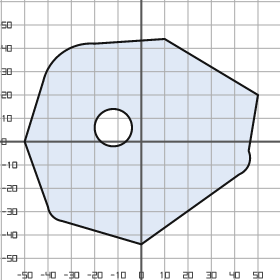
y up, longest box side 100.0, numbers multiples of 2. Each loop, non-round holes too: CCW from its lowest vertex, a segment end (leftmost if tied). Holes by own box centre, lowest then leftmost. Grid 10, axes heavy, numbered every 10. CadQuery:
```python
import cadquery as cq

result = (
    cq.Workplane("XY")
    .moveTo(0.0, -44.0)
    .lineTo(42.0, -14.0)
    .threePointArc((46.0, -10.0), (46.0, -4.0))
    .lineTo(50.0, 20.0)
    .lineTo(10.0, 44.0)
    .lineTo(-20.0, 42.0)
    .threePointArc((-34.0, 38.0), (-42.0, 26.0))
    .lineTo(-50.0, 0.0)
    .lineTo(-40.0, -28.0)
    .threePointArc((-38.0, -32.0), (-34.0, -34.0))
    .close()
    .moveTo(-12.0, 6.0)
    .circle(8.0)
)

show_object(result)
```